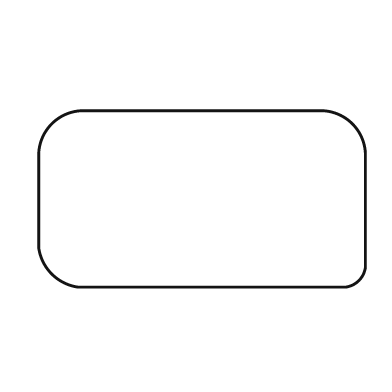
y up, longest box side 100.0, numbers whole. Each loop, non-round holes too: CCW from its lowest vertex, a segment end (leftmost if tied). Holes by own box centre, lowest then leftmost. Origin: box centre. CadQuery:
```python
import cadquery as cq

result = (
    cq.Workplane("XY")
    .moveTo(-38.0, -27.0)
    .lineTo(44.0, -27.0)
    .threePointArc((48.0, -25.0), (50.0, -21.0))
    .lineTo(50.0, 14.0)
    .threePointArc((46.0, 23.0), (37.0, 27.0))
    .lineTo(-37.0, 27.0)
    .threePointArc((-46.0, 23.0), (-50.0, 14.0))
    .lineTo(-50.0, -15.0)
    .threePointArc((-46.0, -23.0), (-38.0, -27.0))
    .close()
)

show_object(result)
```